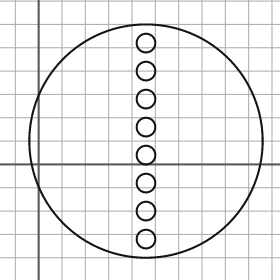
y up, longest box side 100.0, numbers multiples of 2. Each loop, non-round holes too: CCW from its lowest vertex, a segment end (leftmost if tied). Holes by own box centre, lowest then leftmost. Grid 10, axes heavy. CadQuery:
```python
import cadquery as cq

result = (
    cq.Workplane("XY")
    .moveTo(46.0, 10.0)
    .circle(50.0)
    .moveTo(46.0, -32.0)
    .circle(4.0)
    .moveTo(46.0, -20.0)
    .circle(4.0)
    .moveTo(46.0, -8.0)
    .circle(4.0)
    .moveTo(46.0, 4.0)
    .circle(4.0)
    .moveTo(46.0, 16.0)
    .circle(4.0)
    .moveTo(46.0, 28.0)
    .circle(4.0)
    .moveTo(46.0, 40.0)
    .circle(4.0)
    .moveTo(46.0, 52.0)
    .circle(4.0)
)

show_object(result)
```